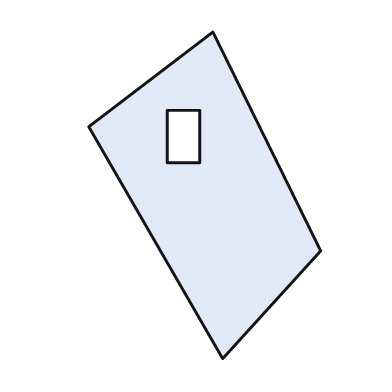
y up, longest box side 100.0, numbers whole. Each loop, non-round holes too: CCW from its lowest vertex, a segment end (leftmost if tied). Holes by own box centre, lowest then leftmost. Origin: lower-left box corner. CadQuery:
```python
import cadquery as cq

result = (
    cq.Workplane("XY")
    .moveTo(41.0, 0.0)
    .lineTo(71.0, 33.0)
    .lineTo(38.0, 100.0)
    .lineTo(0.0, 71.0)
    .close()
    .moveTo(24.0, 60.0)
    .lineTo(34.0, 60.0)
    .lineTo(34.0, 76.0)
    .lineTo(24.0, 76.0)
    .close()
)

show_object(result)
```